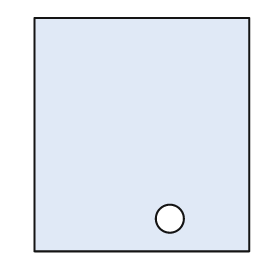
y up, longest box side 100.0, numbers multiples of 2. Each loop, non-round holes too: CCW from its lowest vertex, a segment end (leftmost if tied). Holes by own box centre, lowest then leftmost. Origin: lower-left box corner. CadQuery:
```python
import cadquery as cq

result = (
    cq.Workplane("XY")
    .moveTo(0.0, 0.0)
    .lineTo(92.0, 0.0)
    .lineTo(92.0, 100.0)
    .lineTo(0.0, 100.0)
    .close()
    .moveTo(58.0, 14.0)
    .circle(6.0)
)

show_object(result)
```